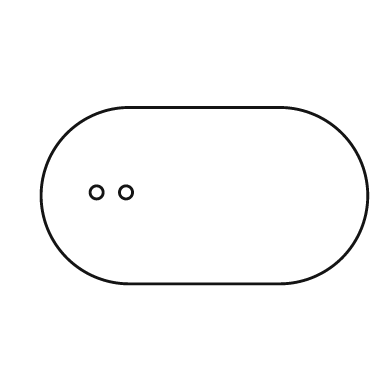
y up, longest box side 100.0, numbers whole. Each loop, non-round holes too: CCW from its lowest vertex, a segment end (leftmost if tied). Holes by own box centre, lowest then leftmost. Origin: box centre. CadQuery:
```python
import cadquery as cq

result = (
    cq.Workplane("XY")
    .moveTo(-23.0, -27.0)
    .lineTo(23.0, -27.0)
    .threePointArc((50.0, 0.0), (23.0, 27.0))
    .lineTo(-23.0, 27.0)
    .threePointArc((-50.0, 0.0), (-23.0, -27.0))
    .close()
    .moveTo(-33.0, 1.0)
    .circle(2.0)
    .moveTo(-24.0, 1.0)
    .circle(2.0)
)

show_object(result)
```